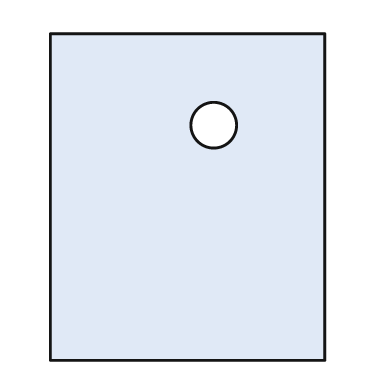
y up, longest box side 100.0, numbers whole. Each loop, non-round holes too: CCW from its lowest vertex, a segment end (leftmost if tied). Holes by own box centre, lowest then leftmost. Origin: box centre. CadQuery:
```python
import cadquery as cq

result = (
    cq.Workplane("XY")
    .moveTo(-42.0, -50.0)
    .lineTo(42.0, -50.0)
    .lineTo(42.0, 50.0)
    .lineTo(-42.0, 50.0)
    .close()
    .moveTo(8.0, 22.0)
    .circle(7.0)
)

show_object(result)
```